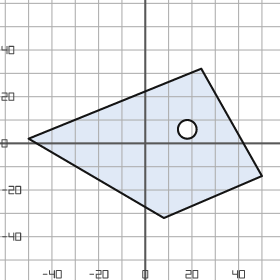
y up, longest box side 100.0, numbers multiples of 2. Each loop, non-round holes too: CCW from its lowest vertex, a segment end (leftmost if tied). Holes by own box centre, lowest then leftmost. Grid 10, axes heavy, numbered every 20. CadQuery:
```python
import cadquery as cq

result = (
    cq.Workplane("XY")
    .moveTo(8.0, -32.0)
    .lineTo(50.0, -14.0)
    .lineTo(24.0, 32.0)
    .lineTo(-50.0, 2.0)
    .close()
    .moveTo(18.0, 6.0)
    .circle(4.0)
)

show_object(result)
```